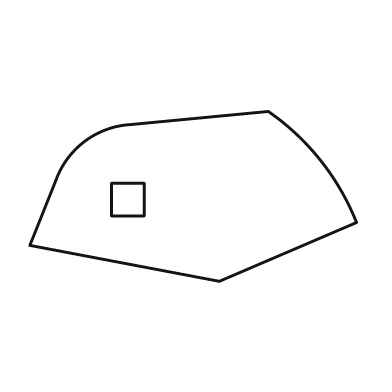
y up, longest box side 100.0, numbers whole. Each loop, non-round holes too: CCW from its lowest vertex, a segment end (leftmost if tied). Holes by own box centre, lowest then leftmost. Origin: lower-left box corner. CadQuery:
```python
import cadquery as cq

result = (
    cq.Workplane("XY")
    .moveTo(58.0, 0.0)
    .lineTo(100.0, 18.0)
    .threePointArc((89.0, 37.0), (73.0, 52.0))
    .lineTo(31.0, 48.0)
    .threePointArc((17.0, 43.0), (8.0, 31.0))
    .lineTo(0.0, 11.0)
    .close()
    .moveTo(25.0, 20.0)
    .lineTo(35.0, 20.0)
    .lineTo(35.0, 30.0)
    .lineTo(25.0, 30.0)
    .close()
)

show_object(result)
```